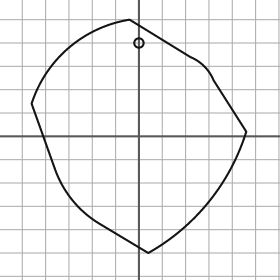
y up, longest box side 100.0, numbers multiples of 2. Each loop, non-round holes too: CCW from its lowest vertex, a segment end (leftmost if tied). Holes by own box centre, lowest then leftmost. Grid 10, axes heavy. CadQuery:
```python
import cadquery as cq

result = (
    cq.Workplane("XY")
    .moveTo(4.0, -50.0)
    .threePointArc((30.0, -28.0), (46.0, 2.0))
    .lineTo(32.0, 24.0)
    .threePointArc((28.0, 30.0), (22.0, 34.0))
    .lineTo(-4.0, 50.0)
    .threePointArc((-30.0, 38.0), (-46.0, 14.0))
    .lineTo(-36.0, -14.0)
    .threePointArc((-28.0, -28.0), (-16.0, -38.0))
    .close()
    .moveTo(0.0, 40.0)
    .circle(2.0)
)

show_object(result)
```